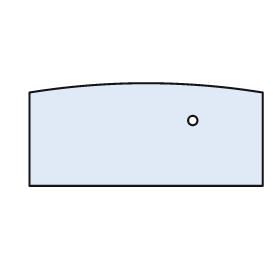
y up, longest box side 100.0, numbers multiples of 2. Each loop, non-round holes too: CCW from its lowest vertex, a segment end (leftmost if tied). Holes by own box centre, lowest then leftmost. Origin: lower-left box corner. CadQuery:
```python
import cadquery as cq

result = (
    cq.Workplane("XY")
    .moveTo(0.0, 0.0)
    .lineTo(100.0, 0.0)
    .lineTo(100.0, 40.0)
    .threePointArc((50.0, 44.0), (0.0, 40.0))
    .close()
    .moveTo(70.0, 28.0)
    .circle(2.0)
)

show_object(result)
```